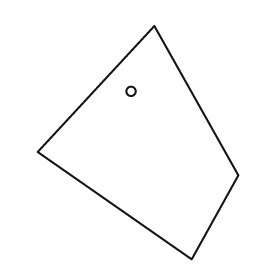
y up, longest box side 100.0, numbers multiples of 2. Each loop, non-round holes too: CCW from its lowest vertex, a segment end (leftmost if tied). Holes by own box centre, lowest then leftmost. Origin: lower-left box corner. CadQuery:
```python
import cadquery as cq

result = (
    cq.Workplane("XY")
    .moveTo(66.0, 0.0)
    .lineTo(86.0, 36.0)
    .lineTo(50.0, 100.0)
    .lineTo(0.0, 46.0)
    .close()
    .moveTo(40.0, 72.0)
    .circle(2.0)
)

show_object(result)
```